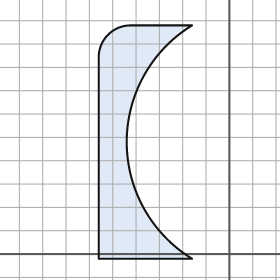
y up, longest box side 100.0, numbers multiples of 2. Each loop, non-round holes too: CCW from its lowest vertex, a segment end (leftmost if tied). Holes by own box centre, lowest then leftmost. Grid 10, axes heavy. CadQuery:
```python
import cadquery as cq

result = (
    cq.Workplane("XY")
    .moveTo(-56.0, -2.0)
    .lineTo(-16.0, -2.0)
    .threePointArc((-44.0, 48.0), (-16.0, 98.0))
    .lineTo(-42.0, 98.0)
    .threePointArc((-52.0, 94.0), (-56.0, 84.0))
    .close()
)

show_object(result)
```